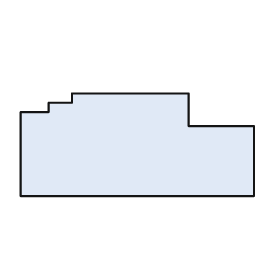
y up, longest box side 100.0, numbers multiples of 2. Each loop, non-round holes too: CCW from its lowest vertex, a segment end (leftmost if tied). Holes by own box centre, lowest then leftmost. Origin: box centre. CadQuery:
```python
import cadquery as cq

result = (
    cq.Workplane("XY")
    .moveTo(-50.0, -22.0)
    .lineTo(50.0, -22.0)
    .lineTo(50.0, 8.0)
    .lineTo(22.0, 8.0)
    .lineTo(22.0, 22.0)
    .lineTo(-28.0, 22.0)
    .lineTo(-28.0, 18.0)
    .lineTo(-38.0, 18.0)
    .lineTo(-38.0, 14.0)
    .lineTo(-50.0, 14.0)
    .close()
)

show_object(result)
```